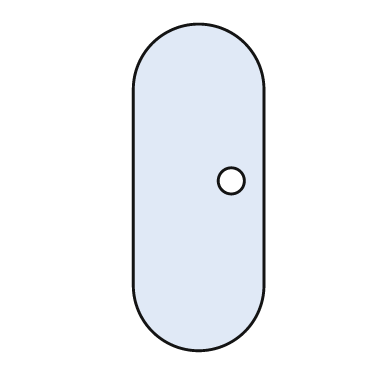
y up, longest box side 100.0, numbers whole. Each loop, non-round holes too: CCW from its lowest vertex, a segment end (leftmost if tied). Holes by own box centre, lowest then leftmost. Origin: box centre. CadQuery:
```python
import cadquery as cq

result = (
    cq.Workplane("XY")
    .moveTo(-20.0, -30.0)
    .threePointArc((0.0, -50.0), (20.0, -30.0))
    .lineTo(20.0, 30.0)
    .threePointArc((0.0, 50.0), (-20.0, 30.0))
    .close()
    .moveTo(10.0, 2.0)
    .circle(4.0)
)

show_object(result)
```